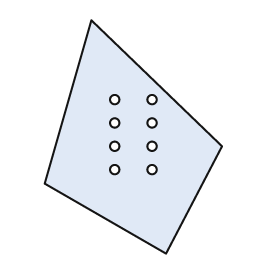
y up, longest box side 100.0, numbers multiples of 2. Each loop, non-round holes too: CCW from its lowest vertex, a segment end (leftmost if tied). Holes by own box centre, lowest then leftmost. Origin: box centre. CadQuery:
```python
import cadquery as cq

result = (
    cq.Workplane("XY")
    .moveTo(14.0, -50.0)
    .lineTo(38.0, -4.0)
    .lineTo(-18.0, 50.0)
    .lineTo(-38.0, -20.0)
    .close()
    .moveTo(-8.0, -14.0)
    .circle(2.0)
    .moveTo(8.0, -14.0)
    .circle(2.0)
    .moveTo(-8.0, -4.0)
    .circle(2.0)
    .moveTo(8.0, -4.0)
    .circle(2.0)
    .moveTo(-8.0, 6.0)
    .circle(2.0)
    .moveTo(8.0, 6.0)
    .circle(2.0)
    .moveTo(-8.0, 16.0)
    .circle(2.0)
    .moveTo(8.0, 16.0)
    .circle(2.0)
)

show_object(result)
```